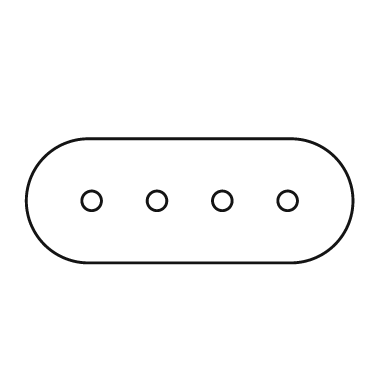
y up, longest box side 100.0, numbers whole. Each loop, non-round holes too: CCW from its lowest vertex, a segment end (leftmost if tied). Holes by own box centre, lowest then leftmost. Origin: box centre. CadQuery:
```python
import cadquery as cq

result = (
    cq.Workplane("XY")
    .moveTo(-31.0, -19.0)
    .lineTo(31.0, -19.0)
    .threePointArc((50.0, 0.0), (31.0, 19.0))
    .lineTo(-31.0, 19.0)
    .threePointArc((-50.0, 0.0), (-31.0, -19.0))
    .close()
    .moveTo(-30.0, 0.0)
    .circle(3.0)
    .moveTo(-10.0, 0.0)
    .circle(3.0)
    .moveTo(10.0, 0.0)
    .circle(3.0)
    .moveTo(30.0, 0.0)
    .circle(3.0)
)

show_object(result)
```